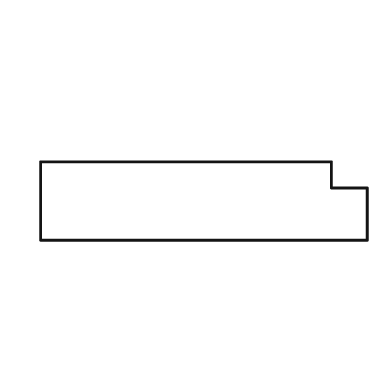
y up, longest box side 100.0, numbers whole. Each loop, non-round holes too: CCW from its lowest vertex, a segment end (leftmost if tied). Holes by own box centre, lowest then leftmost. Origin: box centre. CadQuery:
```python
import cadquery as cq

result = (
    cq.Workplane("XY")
    .moveTo(-50.0, -12.0)
    .lineTo(50.0, -12.0)
    .lineTo(50.0, 4.0)
    .lineTo(39.0, 4.0)
    .lineTo(39.0, 12.0)
    .lineTo(-50.0, 12.0)
    .close()
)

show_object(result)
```